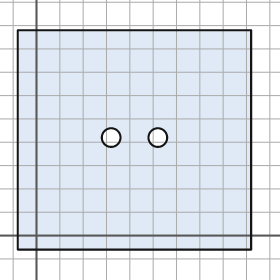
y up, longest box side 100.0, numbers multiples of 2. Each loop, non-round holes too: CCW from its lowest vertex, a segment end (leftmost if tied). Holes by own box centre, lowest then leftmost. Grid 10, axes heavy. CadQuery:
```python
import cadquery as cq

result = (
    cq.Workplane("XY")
    .moveTo(-8.0, -6.0)
    .lineTo(92.0, -6.0)
    .lineTo(92.0, 88.0)
    .lineTo(-8.0, 88.0)
    .close()
    .moveTo(32.0, 42.0)
    .circle(4.0)
    .moveTo(52.0, 42.0)
    .circle(4.0)
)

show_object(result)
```